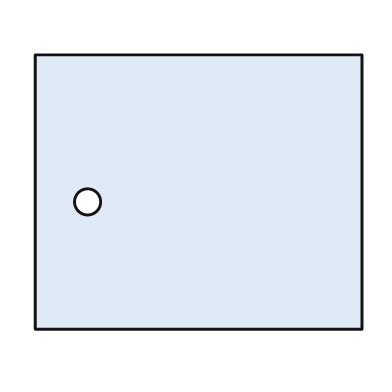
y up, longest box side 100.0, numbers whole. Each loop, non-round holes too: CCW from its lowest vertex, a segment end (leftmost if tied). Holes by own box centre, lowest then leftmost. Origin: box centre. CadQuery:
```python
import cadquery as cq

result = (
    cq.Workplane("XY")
    .moveTo(-50.0, -42.0)
    .lineTo(50.0, -42.0)
    .lineTo(50.0, 42.0)
    .lineTo(-50.0, 42.0)
    .close()
    .moveTo(-34.0, -3.0)
    .circle(4.0)
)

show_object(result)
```